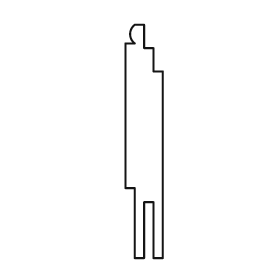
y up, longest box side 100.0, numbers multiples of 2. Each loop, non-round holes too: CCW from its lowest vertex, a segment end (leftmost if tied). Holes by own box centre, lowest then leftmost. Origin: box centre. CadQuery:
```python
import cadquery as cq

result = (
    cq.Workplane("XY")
    .moveTo(-4.0, -50.0)
    .lineTo(0.0, -50.0)
    .lineTo(0.0, -26.0)
    .lineTo(4.0, -26.0)
    .lineTo(4.0, -50.0)
    .lineTo(8.0, -50.0)
    .lineTo(8.0, 30.0)
    .lineTo(4.0, 30.0)
    .lineTo(4.0, 40.0)
    .lineTo(0.0, 40.0)
    .lineTo(0.0, 50.0)
    .lineTo(-4.0, 50.0)
    .threePointArc((-6.0, 46.0), (-4.0, 42.0))
    .lineTo(-8.0, 42.0)
    .lineTo(-8.0, -20.0)
    .lineTo(-4.0, -20.0)
    .close()
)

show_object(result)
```